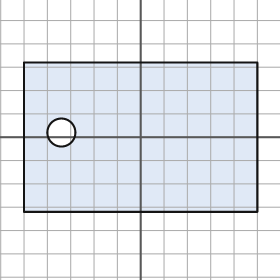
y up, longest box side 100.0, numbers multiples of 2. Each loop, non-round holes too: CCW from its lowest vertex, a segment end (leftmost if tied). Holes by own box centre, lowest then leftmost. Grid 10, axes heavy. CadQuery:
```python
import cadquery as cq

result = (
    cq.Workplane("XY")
    .moveTo(-50.0, -32.0)
    .lineTo(50.0, -32.0)
    .lineTo(50.0, 32.0)
    .lineTo(-50.0, 32.0)
    .close()
    .moveTo(-34.0, 2.0)
    .circle(6.0)
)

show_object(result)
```